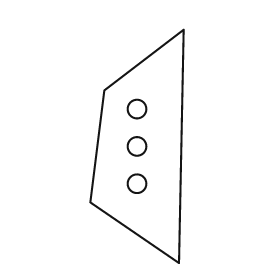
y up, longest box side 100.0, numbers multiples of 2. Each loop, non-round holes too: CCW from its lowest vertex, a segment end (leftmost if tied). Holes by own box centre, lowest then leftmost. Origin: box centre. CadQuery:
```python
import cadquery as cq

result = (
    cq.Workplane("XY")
    .moveTo(18.0, -50.0)
    .lineTo(20.0, 50.0)
    .lineTo(-14.0, 24.0)
    .lineTo(-20.0, -24.0)
    .close()
    .moveTo(0.0, -16.0)
    .circle(4.0)
    .moveTo(0.0, 0.0)
    .circle(4.0)
    .moveTo(0.0, 16.0)
    .circle(4.0)
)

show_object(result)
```